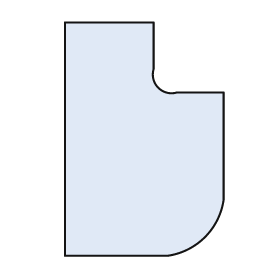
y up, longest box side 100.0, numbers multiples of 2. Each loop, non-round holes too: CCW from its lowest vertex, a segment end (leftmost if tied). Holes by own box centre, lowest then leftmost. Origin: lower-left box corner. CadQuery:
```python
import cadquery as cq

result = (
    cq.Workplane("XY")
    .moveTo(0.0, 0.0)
    .lineTo(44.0, 0.0)
    .threePointArc((60.0, 8.0), (68.0, 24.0))
    .lineTo(68.0, 70.0)
    .lineTo(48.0, 70.0)
    .threePointArc((40.0, 72.0), (38.0, 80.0))
    .lineTo(38.0, 100.0)
    .lineTo(0.0, 100.0)
    .close()
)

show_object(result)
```